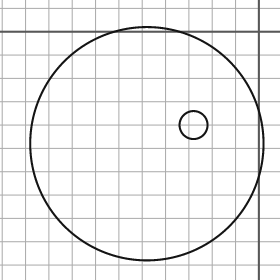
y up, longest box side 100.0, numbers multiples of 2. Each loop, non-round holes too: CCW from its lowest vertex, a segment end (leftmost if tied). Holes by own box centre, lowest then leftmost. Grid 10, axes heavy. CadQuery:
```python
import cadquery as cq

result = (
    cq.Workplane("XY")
    .moveTo(-48.0, -48.0)
    .circle(50.0)
    .moveTo(-28.0, -40.0)
    .circle(6.0)
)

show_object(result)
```